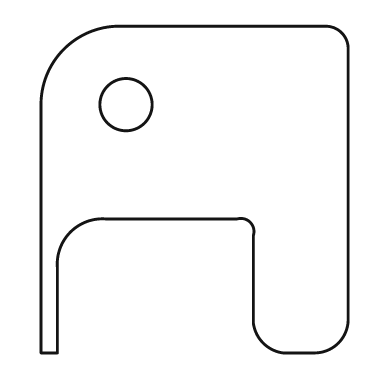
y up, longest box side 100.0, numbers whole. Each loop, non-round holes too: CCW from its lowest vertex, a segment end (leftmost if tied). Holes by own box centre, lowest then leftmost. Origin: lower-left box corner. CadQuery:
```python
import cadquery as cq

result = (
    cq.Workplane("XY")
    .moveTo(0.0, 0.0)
    .lineTo(5.0, 0.0)
    .lineTo(5.0, 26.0)
    .threePointArc((9.0, 37.0), (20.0, 41.0))
    .lineTo(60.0, 41.0)
    .threePointArc((64.0, 40.0), (65.0, 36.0))
    .lineTo(65.0, 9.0)
    .threePointArc((68.0, 3.0), (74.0, 0.0))
    .lineTo(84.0, 0.0)
    .threePointArc((91.0, 3.0), (94.0, 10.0))
    .lineTo(94.0, 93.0)
    .threePointArc((92.0, 98.0), (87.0, 100.0))
    .lineTo(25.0, 100.0)
    .threePointArc((7.0, 93.0), (0.0, 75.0))
    .close()
    .moveTo(26.0, 76.0)
    .circle(8.0)
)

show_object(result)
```